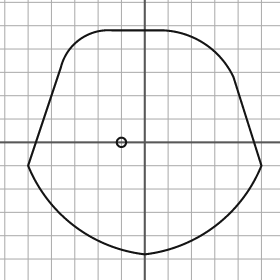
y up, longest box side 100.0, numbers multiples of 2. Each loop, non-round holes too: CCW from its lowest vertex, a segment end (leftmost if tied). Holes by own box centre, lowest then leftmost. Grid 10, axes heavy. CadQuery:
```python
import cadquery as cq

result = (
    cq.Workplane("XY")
    .moveTo(0.0, -48.0)
    .threePointArc((30.0, -36.0), (50.0, -10.0))
    .lineTo(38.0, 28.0)
    .threePointArc((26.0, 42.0), (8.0, 48.0))
    .lineTo(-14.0, 48.0)
    .threePointArc((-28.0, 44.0), (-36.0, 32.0))
    .lineTo(-50.0, -10.0)
    .threePointArc((-30.0, -36.0), (0.0, -48.0))
    .close()
    .moveTo(-10.0, 0.0)
    .circle(2.0)
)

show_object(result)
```